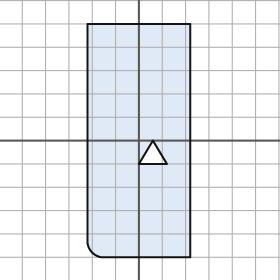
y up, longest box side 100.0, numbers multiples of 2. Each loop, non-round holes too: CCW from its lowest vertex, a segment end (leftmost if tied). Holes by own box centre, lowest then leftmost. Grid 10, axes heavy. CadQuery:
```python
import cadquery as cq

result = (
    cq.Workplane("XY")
    .moveTo(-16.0, -50.0)
    .lineTo(22.0, -50.0)
    .lineTo(22.0, 50.0)
    .lineTo(-22.0, 50.0)
    .lineTo(-22.0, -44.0)
    .threePointArc((-20.0, -48.0), (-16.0, -50.0))
    .close()
    .moveTo(0.0, -10.0)
    .lineTo(12.0, -10.0)
    .lineTo(6.0, 0.0)
    .close()
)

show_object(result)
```